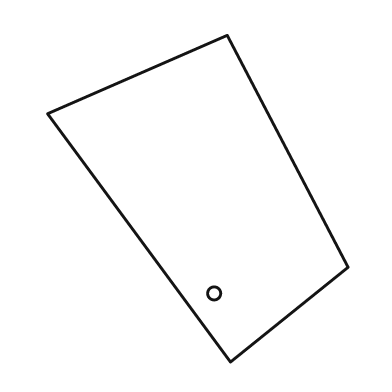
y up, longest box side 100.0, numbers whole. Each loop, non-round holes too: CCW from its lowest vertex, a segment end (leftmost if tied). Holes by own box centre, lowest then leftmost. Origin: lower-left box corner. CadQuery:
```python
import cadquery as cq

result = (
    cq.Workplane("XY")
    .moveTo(56.0, 0.0)
    .lineTo(92.0, 29.0)
    .lineTo(55.0, 100.0)
    .lineTo(0.0, 76.0)
    .close()
    .moveTo(51.0, 21.0)
    .circle(2.0)
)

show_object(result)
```